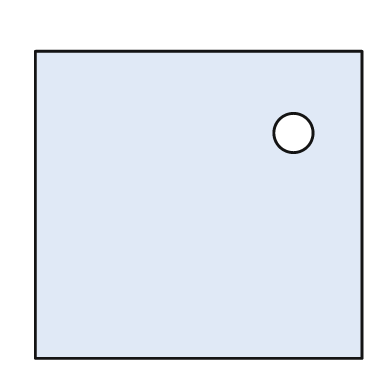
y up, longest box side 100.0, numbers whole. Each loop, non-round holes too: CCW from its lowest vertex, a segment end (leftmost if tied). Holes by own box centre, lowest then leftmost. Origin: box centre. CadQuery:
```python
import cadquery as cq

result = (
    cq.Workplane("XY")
    .moveTo(-50.0, -47.0)
    .lineTo(50.0, -47.0)
    .lineTo(50.0, 47.0)
    .lineTo(-50.0, 47.0)
    .close()
    .moveTo(29.0, 22.0)
    .circle(6.0)
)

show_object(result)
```